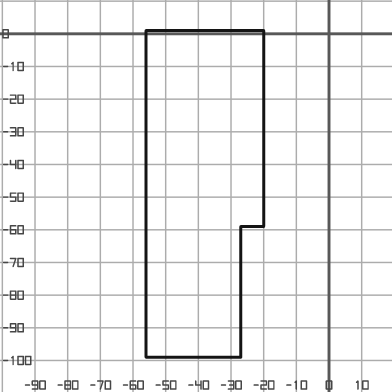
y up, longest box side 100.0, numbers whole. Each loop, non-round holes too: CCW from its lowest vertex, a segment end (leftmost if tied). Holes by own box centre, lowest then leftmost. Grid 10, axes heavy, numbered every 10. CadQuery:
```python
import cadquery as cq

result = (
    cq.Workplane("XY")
    .moveTo(-56.0, -99.0)
    .lineTo(-27.0, -99.0)
    .lineTo(-27.0, -59.0)
    .lineTo(-20.0, -59.0)
    .lineTo(-20.0, 1.0)
    .lineTo(-56.0, 1.0)
    .close()
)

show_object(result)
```